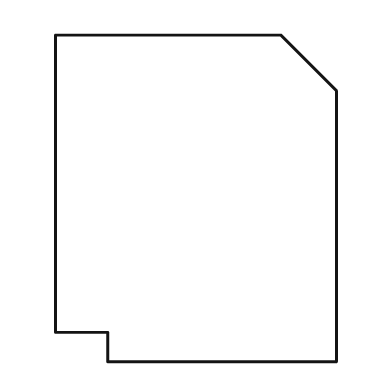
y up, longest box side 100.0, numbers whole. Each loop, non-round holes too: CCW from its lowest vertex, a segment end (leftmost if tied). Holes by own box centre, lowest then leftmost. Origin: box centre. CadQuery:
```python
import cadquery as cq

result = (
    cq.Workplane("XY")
    .moveTo(-27.0, -50.0)
    .lineTo(43.0, -50.0)
    .lineTo(43.0, 33.0)
    .lineTo(26.0, 50.0)
    .lineTo(-43.0, 50.0)
    .lineTo(-43.0, -41.0)
    .lineTo(-27.0, -41.0)
    .close()
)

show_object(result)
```